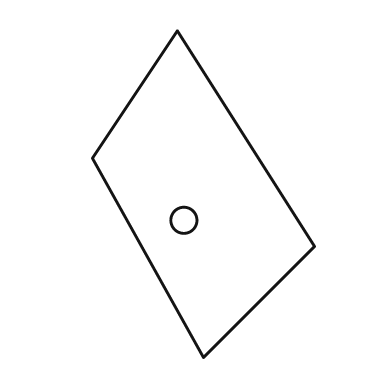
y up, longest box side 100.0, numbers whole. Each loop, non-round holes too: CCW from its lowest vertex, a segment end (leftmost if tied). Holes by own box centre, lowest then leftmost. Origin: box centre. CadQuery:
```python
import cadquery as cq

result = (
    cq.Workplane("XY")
    .moveTo(0.0, -50.0)
    .lineTo(34.0, -16.0)
    .lineTo(-8.0, 50.0)
    .lineTo(-34.0, 11.0)
    .close()
    .moveTo(-6.0, -8.0)
    .circle(4.0)
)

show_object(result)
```